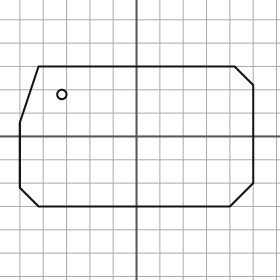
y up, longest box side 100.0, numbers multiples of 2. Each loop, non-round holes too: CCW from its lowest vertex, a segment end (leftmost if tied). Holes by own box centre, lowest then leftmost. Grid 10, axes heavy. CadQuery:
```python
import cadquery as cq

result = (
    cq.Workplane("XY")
    .moveTo(-42.0, -30.0)
    .lineTo(40.0, -30.0)
    .lineTo(50.0, -20.0)
    .lineTo(50.0, 22.0)
    .lineTo(42.0, 30.0)
    .lineTo(-42.0, 30.0)
    .lineTo(-50.0, 6.0)
    .lineTo(-50.0, -22.0)
    .close()
    .moveTo(-32.0, 18.0)
    .circle(2.0)
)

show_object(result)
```